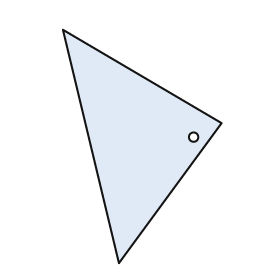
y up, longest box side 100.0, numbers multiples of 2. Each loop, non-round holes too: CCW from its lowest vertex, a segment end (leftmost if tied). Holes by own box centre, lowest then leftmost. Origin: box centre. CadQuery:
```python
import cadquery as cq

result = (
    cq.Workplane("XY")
    .moveTo(-10.0, -50.0)
    .lineTo(34.0, 10.0)
    .lineTo(-34.0, 50.0)
    .close()
    .moveTo(22.0, 4.0)
    .circle(2.0)
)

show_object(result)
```